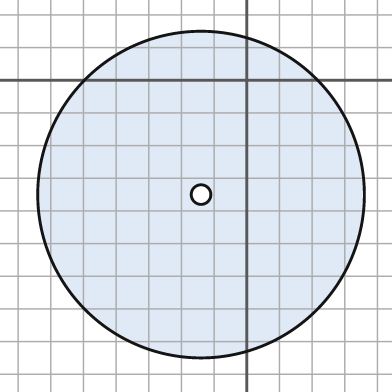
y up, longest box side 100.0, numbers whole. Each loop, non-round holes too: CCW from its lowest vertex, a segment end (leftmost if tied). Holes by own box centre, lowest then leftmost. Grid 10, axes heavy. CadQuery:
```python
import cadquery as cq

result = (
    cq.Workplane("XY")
    .moveTo(-14.0, -35.0)
    .circle(50.0)
    .moveTo(-14.0, -35.0)
    .circle(3.0)
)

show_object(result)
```